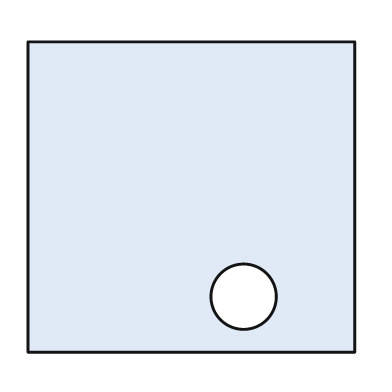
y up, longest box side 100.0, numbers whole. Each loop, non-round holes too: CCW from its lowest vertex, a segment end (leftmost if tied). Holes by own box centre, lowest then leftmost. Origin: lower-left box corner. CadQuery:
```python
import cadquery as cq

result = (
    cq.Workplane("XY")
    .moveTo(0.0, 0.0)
    .lineTo(100.0, 0.0)
    .lineTo(100.0, 95.0)
    .lineTo(0.0, 95.0)
    .close()
    .moveTo(66.0, 17.0)
    .circle(10.0)
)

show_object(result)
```